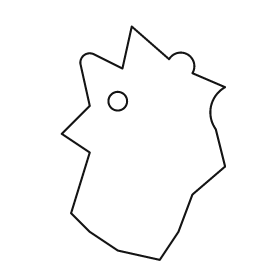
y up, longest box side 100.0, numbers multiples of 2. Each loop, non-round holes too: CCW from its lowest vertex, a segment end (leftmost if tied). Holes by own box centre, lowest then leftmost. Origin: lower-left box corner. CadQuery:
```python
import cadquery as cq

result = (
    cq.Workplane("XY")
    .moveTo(42.0, 0.0)
    .lineTo(50.0, 12.0)
    .lineTo(56.0, 28.0)
    .lineTo(70.0, 40.0)
    .lineTo(66.0, 56.0)
    .threePointArc((64.0, 66.0), (70.0, 74.0))
    .lineTo(56.0, 80.0)
    .threePointArc((54.0, 88.0), (46.0, 86.0))
    .lineTo(30.0, 100.0)
    .lineTo(26.0, 82.0)
    .lineTo(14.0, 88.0)
    .threePointArc((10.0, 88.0), (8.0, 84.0))
    .lineTo(12.0, 66.0)
    .lineTo(0.0, 54.0)
    .lineTo(12.0, 46.0)
    .lineTo(4.0, 20.0)
    .lineTo(12.0, 12.0)
    .lineTo(24.0, 4.0)
    .close()
    .moveTo(24.0, 68.0)
    .circle(4.0)
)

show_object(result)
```